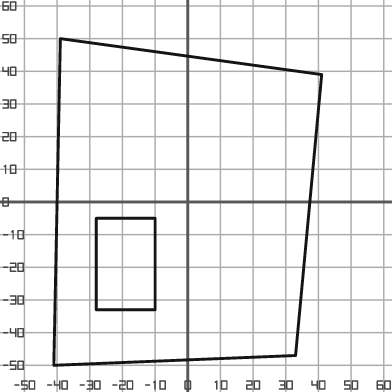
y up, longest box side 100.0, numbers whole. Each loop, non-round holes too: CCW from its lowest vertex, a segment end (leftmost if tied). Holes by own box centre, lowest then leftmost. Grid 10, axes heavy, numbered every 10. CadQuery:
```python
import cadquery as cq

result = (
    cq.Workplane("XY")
    .moveTo(-41.0, -50.0)
    .lineTo(33.0, -47.0)
    .lineTo(41.0, 39.0)
    .lineTo(-39.0, 50.0)
    .close()
    .moveTo(-28.0, -33.0)
    .lineTo(-10.0, -33.0)
    .lineTo(-10.0, -5.0)
    .lineTo(-28.0, -5.0)
    .close()
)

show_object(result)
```